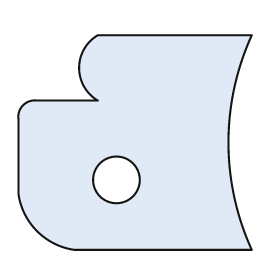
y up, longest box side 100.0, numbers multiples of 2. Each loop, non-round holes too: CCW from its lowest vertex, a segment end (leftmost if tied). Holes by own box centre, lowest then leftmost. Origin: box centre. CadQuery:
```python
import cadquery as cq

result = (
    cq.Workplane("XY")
    .moveTo(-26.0, -46.0)
    .lineTo(50.0, -46.0)
    .threePointArc((40.0, 0.0), (50.0, 46.0))
    .lineTo(-16.0, 46.0)
    .threePointArc((-24.0, 32.0), (-16.0, 18.0))
    .lineTo(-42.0, 18.0)
    .threePointArc((-48.0, 16.0), (-50.0, 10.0))
    .lineTo(-50.0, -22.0)
    .threePointArc((-42.0, -38.0), (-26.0, -46.0))
    .close()
    .moveTo(-8.0, -16.0)
    .circle(10.0)
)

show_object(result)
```